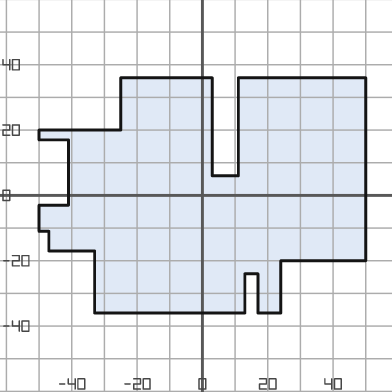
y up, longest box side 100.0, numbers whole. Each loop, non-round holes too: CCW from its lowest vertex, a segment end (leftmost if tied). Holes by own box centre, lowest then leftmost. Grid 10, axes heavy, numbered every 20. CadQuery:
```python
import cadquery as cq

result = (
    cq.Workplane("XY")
    .moveTo(-33.0, -36.0)
    .lineTo(13.0, -36.0)
    .lineTo(13.0, -24.0)
    .lineTo(17.0, -24.0)
    .lineTo(17.0, -36.0)
    .lineTo(24.0, -36.0)
    .lineTo(24.0, -20.0)
    .lineTo(50.0, -20.0)
    .lineTo(50.0, 36.0)
    .lineTo(11.0, 36.0)
    .lineTo(11.0, 6.0)
    .lineTo(3.0, 6.0)
    .lineTo(3.0, 36.0)
    .lineTo(-25.0, 36.0)
    .lineTo(-25.0, 20.0)
    .lineTo(-50.0, 20.0)
    .lineTo(-50.0, 17.0)
    .lineTo(-41.0, 17.0)
    .lineTo(-41.0, -3.0)
    .lineTo(-50.0, -3.0)
    .lineTo(-50.0, -11.0)
    .lineTo(-47.0, -11.0)
    .lineTo(-47.0, -17.0)
    .lineTo(-33.0, -17.0)
    .close()
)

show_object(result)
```